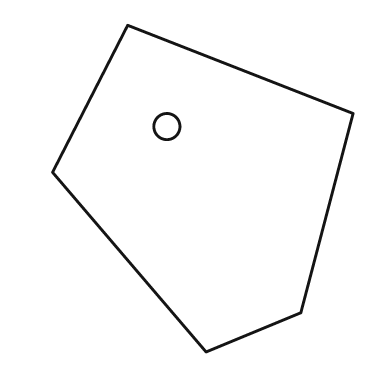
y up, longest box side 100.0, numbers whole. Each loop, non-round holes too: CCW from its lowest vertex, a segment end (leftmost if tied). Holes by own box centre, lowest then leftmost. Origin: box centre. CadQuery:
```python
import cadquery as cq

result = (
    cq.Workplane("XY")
    .moveTo(1.0, -50.0)
    .lineTo(30.0, -38.0)
    .lineTo(46.0, 23.0)
    .lineTo(-23.0, 50.0)
    .lineTo(-46.0, 5.0)
    .close()
    .moveTo(-11.0, 19.0)
    .circle(4.0)
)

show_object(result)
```